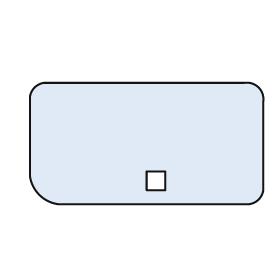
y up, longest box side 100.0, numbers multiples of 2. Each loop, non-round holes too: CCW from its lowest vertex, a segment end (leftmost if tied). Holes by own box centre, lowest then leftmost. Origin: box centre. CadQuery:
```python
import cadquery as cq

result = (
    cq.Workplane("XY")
    .moveTo(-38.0, -26.0)
    .lineTo(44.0, -26.0)
    .threePointArc((48.0, -24.0), (50.0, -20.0))
    .lineTo(50.0, 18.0)
    .threePointArc((48.0, 24.0), (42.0, 26.0))
    .lineTo(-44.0, 26.0)
    .threePointArc((-48.0, 24.0), (-50.0, 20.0))
    .lineTo(-50.0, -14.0)
    .threePointArc((-46.0, -22.0), (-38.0, -26.0))
    .close()
    .moveTo(0.0, -20.0)
    .lineTo(8.0, -20.0)
    .lineTo(8.0, -12.0)
    .lineTo(0.0, -12.0)
    .close()
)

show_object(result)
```